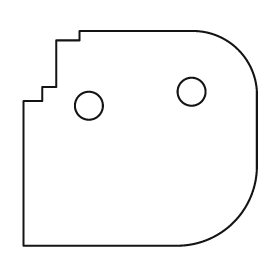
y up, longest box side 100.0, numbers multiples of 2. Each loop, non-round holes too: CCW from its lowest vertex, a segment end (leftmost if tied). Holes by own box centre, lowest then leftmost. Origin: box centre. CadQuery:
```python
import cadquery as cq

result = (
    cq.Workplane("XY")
    .moveTo(-50.0, -46.0)
    .lineTo(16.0, -46.0)
    .threePointArc((40.0, -36.0), (50.0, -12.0))
    .lineTo(50.0, 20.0)
    .threePointArc((42.0, 38.0), (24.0, 46.0))
    .lineTo(-26.0, 46.0)
    .lineTo(-26.0, 42.0)
    .lineTo(-36.0, 42.0)
    .lineTo(-36.0, 22.0)
    .lineTo(-42.0, 22.0)
    .lineTo(-42.0, 16.0)
    .lineTo(-50.0, 16.0)
    .close()
    .moveTo(-22.0, 14.0)
    .circle(6.0)
    .moveTo(22.0, 20.0)
    .circle(6.0)
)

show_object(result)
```